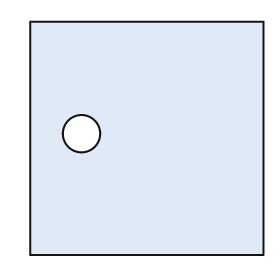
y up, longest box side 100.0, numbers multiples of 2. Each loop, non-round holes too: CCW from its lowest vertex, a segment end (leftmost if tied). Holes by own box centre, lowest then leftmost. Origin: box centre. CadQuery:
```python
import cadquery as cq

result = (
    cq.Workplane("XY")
    .moveTo(-50.0, -50.0)
    .lineTo(50.0, -50.0)
    .lineTo(50.0, 50.0)
    .lineTo(-50.0, 50.0)
    .close()
    .moveTo(-28.0, 2.0)
    .circle(8.0)
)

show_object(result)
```